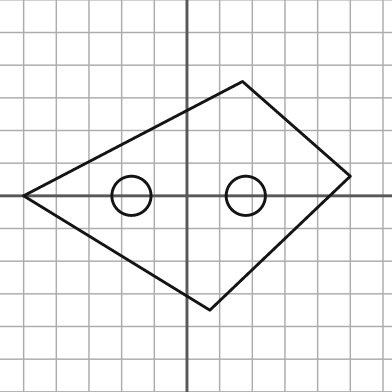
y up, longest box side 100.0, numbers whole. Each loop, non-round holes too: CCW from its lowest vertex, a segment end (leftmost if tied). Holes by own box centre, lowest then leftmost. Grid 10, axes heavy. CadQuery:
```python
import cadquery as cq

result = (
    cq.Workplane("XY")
    .moveTo(7.0, -35.0)
    .lineTo(50.0, 6.0)
    .lineTo(17.0, 35.0)
    .lineTo(-50.0, 0.0)
    .close()
    .moveTo(-17.0, 0.0)
    .circle(6.0)
    .moveTo(18.0, 0.0)
    .circle(6.0)
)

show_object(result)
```